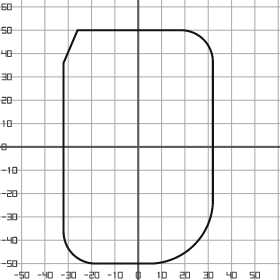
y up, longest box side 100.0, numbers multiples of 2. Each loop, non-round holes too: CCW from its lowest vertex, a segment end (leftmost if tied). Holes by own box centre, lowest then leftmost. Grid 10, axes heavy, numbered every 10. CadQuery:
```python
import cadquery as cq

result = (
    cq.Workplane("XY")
    .moveTo(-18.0, -50.0)
    .lineTo(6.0, -50.0)
    .threePointArc((24.0, -42.0), (32.0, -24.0))
    .lineTo(32.0, 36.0)
    .threePointArc((28.0, 46.0), (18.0, 50.0))
    .lineTo(-26.0, 50.0)
    .lineTo(-32.0, 36.0)
    .lineTo(-32.0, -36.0)
    .threePointArc((-28.0, -46.0), (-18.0, -50.0))
    .close()
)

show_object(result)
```